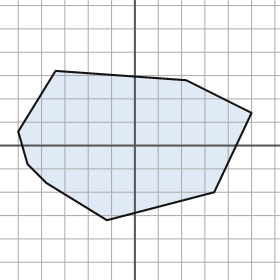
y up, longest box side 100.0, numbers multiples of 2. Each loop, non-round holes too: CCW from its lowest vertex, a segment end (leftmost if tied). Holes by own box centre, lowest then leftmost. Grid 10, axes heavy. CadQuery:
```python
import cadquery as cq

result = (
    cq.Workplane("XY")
    .moveTo(-12.0, -32.0)
    .lineTo(34.0, -20.0)
    .lineTo(50.0, 14.0)
    .lineTo(22.0, 28.0)
    .lineTo(-34.0, 32.0)
    .lineTo(-50.0, 6.0)
    .lineTo(-46.0, -8.0)
    .lineTo(-38.0, -16.0)
    .close()
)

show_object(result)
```